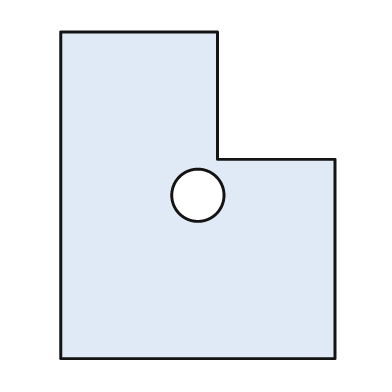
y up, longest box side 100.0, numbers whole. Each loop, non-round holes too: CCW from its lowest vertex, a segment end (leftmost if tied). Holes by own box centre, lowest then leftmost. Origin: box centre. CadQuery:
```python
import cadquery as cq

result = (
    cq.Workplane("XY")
    .moveTo(-42.0, -50.0)
    .lineTo(42.0, -50.0)
    .lineTo(42.0, 11.0)
    .lineTo(6.0, 11.0)
    .lineTo(6.0, 50.0)
    .lineTo(-42.0, 50.0)
    .close()
    .moveTo(0.0, 0.0)
    .circle(8.0)
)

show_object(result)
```